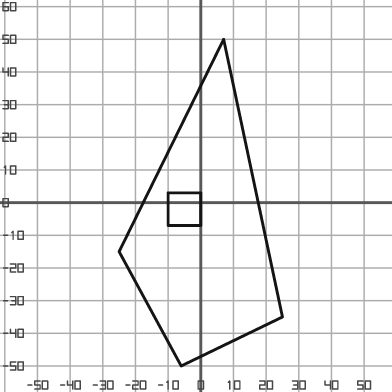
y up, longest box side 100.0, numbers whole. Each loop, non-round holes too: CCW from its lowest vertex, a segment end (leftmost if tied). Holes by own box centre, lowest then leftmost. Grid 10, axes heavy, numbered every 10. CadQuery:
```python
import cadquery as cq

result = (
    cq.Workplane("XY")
    .moveTo(-6.0, -50.0)
    .lineTo(25.0, -35.0)
    .lineTo(7.0, 50.0)
    .lineTo(-25.0, -15.0)
    .close()
    .moveTo(-10.0, -7.0)
    .lineTo(0.0, -7.0)
    .lineTo(0.0, 3.0)
    .lineTo(-10.0, 3.0)
    .close()
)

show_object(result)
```